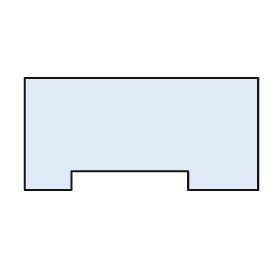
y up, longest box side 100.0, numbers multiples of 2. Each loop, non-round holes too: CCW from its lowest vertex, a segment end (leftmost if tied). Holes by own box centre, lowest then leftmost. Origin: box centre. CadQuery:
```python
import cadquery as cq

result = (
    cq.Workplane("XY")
    .moveTo(-50.0, -24.0)
    .lineTo(-30.0, -24.0)
    .lineTo(-30.0, -16.0)
    .lineTo(20.0, -16.0)
    .lineTo(20.0, -24.0)
    .lineTo(50.0, -24.0)
    .lineTo(50.0, 24.0)
    .lineTo(-50.0, 24.0)
    .close()
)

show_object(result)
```